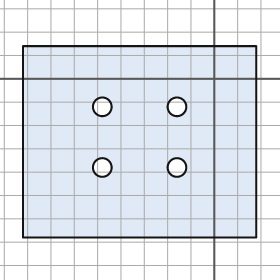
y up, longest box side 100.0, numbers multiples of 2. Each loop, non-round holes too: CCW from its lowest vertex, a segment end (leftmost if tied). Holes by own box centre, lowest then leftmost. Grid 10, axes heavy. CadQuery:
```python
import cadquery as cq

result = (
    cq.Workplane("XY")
    .moveTo(-82.0, -68.0)
    .lineTo(18.0, -68.0)
    .lineTo(18.0, 14.0)
    .lineTo(-82.0, 14.0)
    .close()
    .moveTo(-48.0, -38.0)
    .circle(4.0)
    .moveTo(-16.0, -38.0)
    .circle(4.0)
    .moveTo(-48.0, -12.0)
    .circle(4.0)
    .moveTo(-16.0, -12.0)
    .circle(4.0)
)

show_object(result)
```